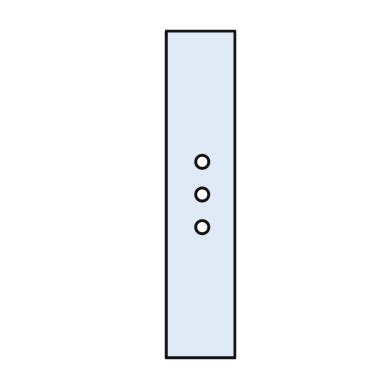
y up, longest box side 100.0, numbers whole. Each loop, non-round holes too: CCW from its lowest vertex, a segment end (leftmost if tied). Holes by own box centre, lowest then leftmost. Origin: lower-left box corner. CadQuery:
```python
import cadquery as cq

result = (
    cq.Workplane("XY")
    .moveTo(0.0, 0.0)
    .lineTo(21.0, 0.0)
    .lineTo(21.0, 100.0)
    .lineTo(0.0, 100.0)
    .close()
    .moveTo(11.0, 40.0)
    .circle(2.0)
    .moveTo(11.0, 50.0)
    .circle(2.0)
    .moveTo(11.0, 60.0)
    .circle(2.0)
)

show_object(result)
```